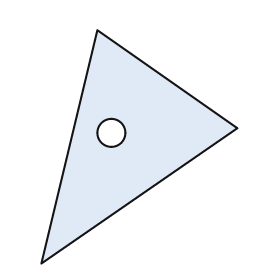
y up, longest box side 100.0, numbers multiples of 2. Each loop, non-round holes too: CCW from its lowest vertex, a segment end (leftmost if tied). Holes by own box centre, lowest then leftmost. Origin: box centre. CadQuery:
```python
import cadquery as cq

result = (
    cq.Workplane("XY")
    .moveTo(-42.0, -50.0)
    .lineTo(42.0, 8.0)
    .lineTo(-18.0, 50.0)
    .close()
    .moveTo(-12.0, 6.0)
    .circle(6.0)
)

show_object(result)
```